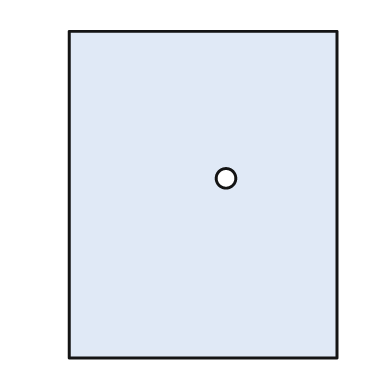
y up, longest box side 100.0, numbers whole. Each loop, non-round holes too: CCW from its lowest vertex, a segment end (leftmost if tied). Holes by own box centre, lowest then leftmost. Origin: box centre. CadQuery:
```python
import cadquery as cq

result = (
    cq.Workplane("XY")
    .moveTo(-41.0, -50.0)
    .lineTo(41.0, -50.0)
    .lineTo(41.0, 50.0)
    .lineTo(-41.0, 50.0)
    .close()
    .moveTo(7.0, 5.0)
    .circle(3.0)
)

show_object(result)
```